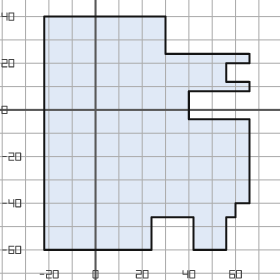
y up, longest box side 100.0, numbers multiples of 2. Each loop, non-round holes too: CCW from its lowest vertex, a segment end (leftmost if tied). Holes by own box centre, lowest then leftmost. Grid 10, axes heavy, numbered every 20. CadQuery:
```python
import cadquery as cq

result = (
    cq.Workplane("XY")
    .moveTo(-22.0, -60.0)
    .lineTo(24.0, -60.0)
    .lineTo(24.0, -46.0)
    .lineTo(42.0, -46.0)
    .lineTo(42.0, -60.0)
    .lineTo(56.0, -60.0)
    .lineTo(56.0, -46.0)
    .lineTo(60.0, -46.0)
    .lineTo(60.0, -40.0)
    .lineTo(66.0, -40.0)
    .lineTo(66.0, -4.0)
    .lineTo(40.0, -4.0)
    .lineTo(40.0, 8.0)
    .lineTo(66.0, 8.0)
    .lineTo(66.0, 12.0)
    .lineTo(56.0, 12.0)
    .lineTo(56.0, 20.0)
    .lineTo(66.0, 20.0)
    .lineTo(66.0, 24.0)
    .lineTo(30.0, 24.0)
    .lineTo(30.0, 40.0)
    .lineTo(-22.0, 40.0)
    .close()
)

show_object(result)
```